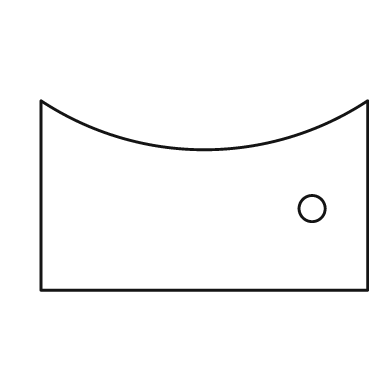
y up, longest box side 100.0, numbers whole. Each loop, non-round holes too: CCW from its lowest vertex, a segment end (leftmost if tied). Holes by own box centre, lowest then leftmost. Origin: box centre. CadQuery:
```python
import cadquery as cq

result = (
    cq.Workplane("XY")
    .moveTo(-50.0, -29.0)
    .lineTo(50.0, -29.0)
    .lineTo(50.0, 29.0)
    .threePointArc((0.0, 14.0), (-50.0, 29.0))
    .close()
    .moveTo(33.0, -4.0)
    .circle(4.0)
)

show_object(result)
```